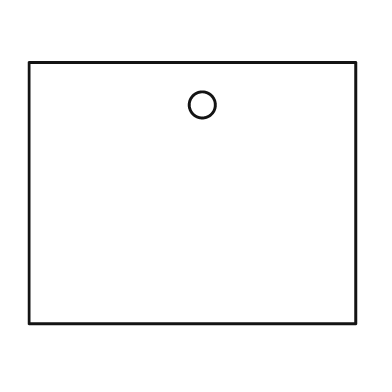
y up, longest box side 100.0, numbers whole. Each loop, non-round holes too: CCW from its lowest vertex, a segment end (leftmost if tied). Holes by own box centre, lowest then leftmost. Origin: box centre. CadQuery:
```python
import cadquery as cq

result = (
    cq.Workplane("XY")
    .moveTo(-50.0, -40.0)
    .lineTo(50.0, -40.0)
    .lineTo(50.0, 40.0)
    .lineTo(-50.0, 40.0)
    .close()
    .moveTo(3.0, 27.0)
    .circle(4.0)
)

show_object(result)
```